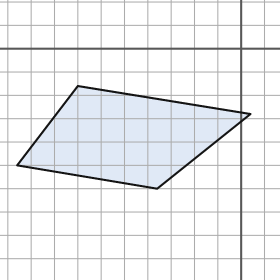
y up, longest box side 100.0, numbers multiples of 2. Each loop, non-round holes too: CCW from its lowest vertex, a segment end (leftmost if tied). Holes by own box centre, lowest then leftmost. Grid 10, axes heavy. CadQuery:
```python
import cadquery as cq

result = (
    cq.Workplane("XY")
    .moveTo(-36.0, -60.0)
    .lineTo(4.0, -28.0)
    .lineTo(-70.0, -16.0)
    .lineTo(-96.0, -50.0)
    .close()
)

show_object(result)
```